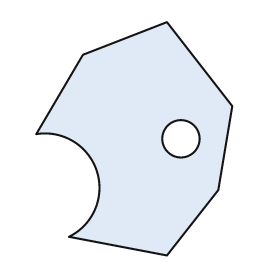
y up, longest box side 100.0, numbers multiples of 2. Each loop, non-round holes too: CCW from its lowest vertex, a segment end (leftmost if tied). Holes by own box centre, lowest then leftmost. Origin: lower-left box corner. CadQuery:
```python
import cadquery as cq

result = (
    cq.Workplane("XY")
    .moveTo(56.0, 0.0)
    .lineTo(78.0, 28.0)
    .lineTo(84.0, 64.0)
    .lineTo(56.0, 100.0)
    .lineTo(20.0, 86.0)
    .lineTo(0.0, 52.0)
    .threePointArc((26.0, 36.0), (14.0, 8.0))
    .close()
    .moveTo(62.0, 50.0)
    .circle(8.0)
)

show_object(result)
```